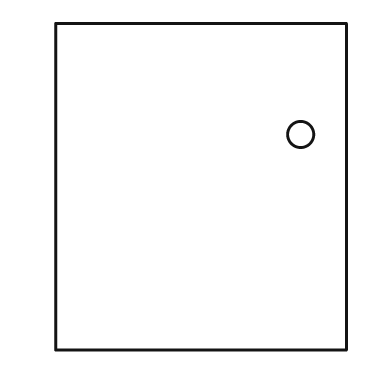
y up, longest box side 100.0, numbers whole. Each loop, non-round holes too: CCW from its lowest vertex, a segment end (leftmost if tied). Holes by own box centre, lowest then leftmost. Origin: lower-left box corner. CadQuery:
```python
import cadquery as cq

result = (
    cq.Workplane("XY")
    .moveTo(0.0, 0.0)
    .lineTo(89.0, 0.0)
    .lineTo(89.0, 100.0)
    .lineTo(0.0, 100.0)
    .close()
    .moveTo(75.0, 66.0)
    .circle(4.0)
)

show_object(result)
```